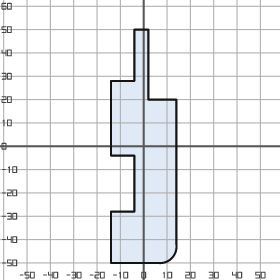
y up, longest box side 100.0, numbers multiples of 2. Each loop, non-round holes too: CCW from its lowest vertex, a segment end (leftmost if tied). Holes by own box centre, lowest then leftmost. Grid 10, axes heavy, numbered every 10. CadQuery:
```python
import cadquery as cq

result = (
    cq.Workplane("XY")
    .moveTo(-14.0, -50.0)
    .lineTo(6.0, -50.0)
    .threePointArc((12.0, -48.0), (14.0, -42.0))
    .lineTo(14.0, 20.0)
    .lineTo(2.0, 20.0)
    .lineTo(2.0, 50.0)
    .lineTo(-4.0, 50.0)
    .lineTo(-4.0, 28.0)
    .lineTo(-14.0, 28.0)
    .lineTo(-14.0, -4.0)
    .lineTo(-4.0, -4.0)
    .lineTo(-4.0, -28.0)
    .lineTo(-14.0, -28.0)
    .close()
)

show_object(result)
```